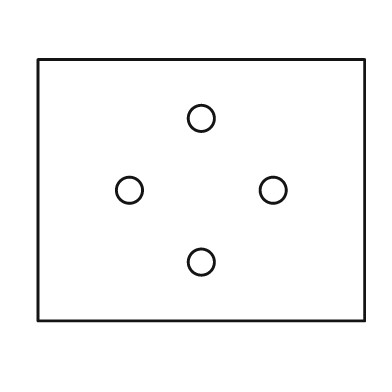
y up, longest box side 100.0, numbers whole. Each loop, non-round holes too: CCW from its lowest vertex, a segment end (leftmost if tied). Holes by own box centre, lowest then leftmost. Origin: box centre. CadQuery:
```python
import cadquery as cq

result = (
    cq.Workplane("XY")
    .moveTo(-50.0, -40.0)
    .lineTo(50.0, -40.0)
    .lineTo(50.0, 40.0)
    .lineTo(-50.0, 40.0)
    .close()
    .moveTo(0.0, -22.0)
    .circle(4.0)
    .moveTo(-22.0, 0.0)
    .circle(4.0)
    .moveTo(22.0, 0.0)
    .circle(4.0)
    .moveTo(0.0, 22.0)
    .circle(4.0)
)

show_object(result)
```